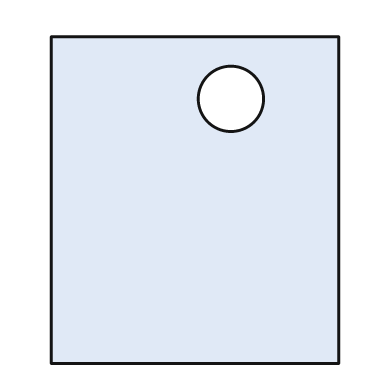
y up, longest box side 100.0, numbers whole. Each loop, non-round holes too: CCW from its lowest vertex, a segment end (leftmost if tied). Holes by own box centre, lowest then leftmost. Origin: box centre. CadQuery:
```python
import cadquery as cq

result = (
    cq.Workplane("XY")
    .moveTo(-44.0, -50.0)
    .lineTo(44.0, -50.0)
    .lineTo(44.0, 50.0)
    .lineTo(-44.0, 50.0)
    .close()
    .moveTo(11.0, 31.0)
    .circle(10.0)
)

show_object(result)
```